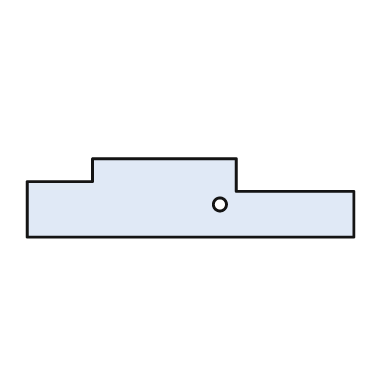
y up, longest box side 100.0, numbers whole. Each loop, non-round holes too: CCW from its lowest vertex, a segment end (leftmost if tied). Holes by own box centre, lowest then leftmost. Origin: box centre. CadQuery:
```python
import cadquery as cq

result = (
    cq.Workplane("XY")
    .moveTo(-50.0, -12.0)
    .lineTo(50.0, -12.0)
    .lineTo(50.0, 2.0)
    .lineTo(14.0, 2.0)
    .lineTo(14.0, 12.0)
    .lineTo(-30.0, 12.0)
    .lineTo(-30.0, 5.0)
    .lineTo(-50.0, 5.0)
    .close()
    .moveTo(9.0, -2.0)
    .circle(2.0)
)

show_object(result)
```